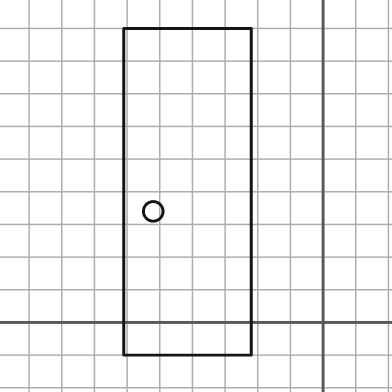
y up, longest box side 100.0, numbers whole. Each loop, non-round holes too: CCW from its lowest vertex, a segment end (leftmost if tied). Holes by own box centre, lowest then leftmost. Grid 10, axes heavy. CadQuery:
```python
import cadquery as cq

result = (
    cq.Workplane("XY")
    .moveTo(-61.0, -10.0)
    .lineTo(-22.0, -10.0)
    .lineTo(-22.0, 90.0)
    .lineTo(-61.0, 90.0)
    .close()
    .moveTo(-52.0, 34.0)
    .circle(3.0)
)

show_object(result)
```